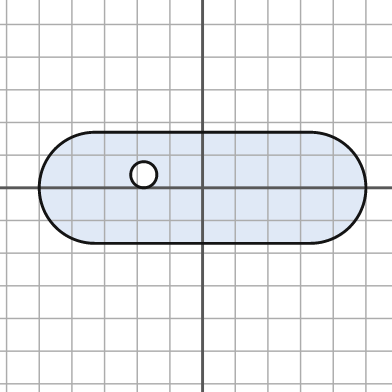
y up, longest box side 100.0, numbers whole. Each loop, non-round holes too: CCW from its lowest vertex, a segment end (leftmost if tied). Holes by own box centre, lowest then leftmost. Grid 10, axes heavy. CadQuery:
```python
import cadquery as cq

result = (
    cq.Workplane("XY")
    .moveTo(-33.0, -17.0)
    .lineTo(33.0, -17.0)
    .threePointArc((50.0, 0.0), (33.0, 17.0))
    .lineTo(-33.0, 17.0)
    .threePointArc((-50.0, 0.0), (-33.0, -17.0))
    .close()
    .moveTo(-18.0, 4.0)
    .circle(4.0)
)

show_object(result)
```